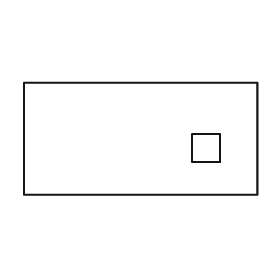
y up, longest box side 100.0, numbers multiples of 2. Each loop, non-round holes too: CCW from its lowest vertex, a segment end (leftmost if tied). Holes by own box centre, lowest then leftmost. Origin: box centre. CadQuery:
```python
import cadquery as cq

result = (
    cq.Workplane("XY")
    .moveTo(-50.0, -24.0)
    .lineTo(50.0, -24.0)
    .lineTo(50.0, 24.0)
    .lineTo(-50.0, 24.0)
    .close()
    .moveTo(22.0, -10.0)
    .lineTo(34.0, -10.0)
    .lineTo(34.0, 2.0)
    .lineTo(22.0, 2.0)
    .close()
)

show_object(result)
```